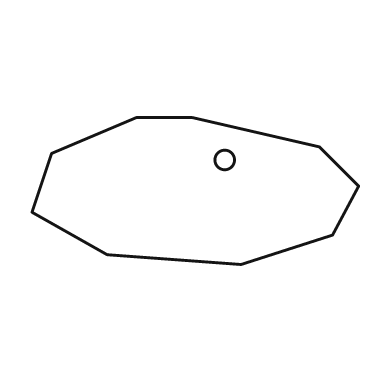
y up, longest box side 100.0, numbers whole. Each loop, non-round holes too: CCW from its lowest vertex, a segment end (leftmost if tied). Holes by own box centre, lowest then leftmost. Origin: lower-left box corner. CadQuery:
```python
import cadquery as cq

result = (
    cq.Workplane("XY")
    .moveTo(64.0, 0.0)
    .lineTo(92.0, 9.0)
    .lineTo(100.0, 24.0)
    .lineTo(88.0, 36.0)
    .lineTo(49.0, 45.0)
    .lineTo(32.0, 45.0)
    .lineTo(6.0, 34.0)
    .lineTo(0.0, 16.0)
    .lineTo(23.0, 3.0)
    .close()
    .moveTo(59.0, 32.0)
    .circle(3.0)
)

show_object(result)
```